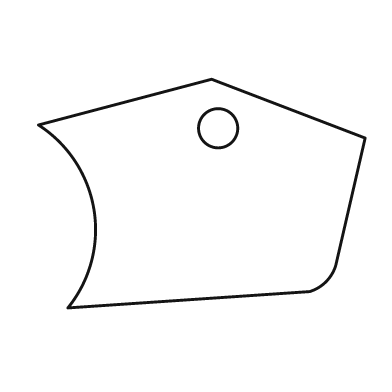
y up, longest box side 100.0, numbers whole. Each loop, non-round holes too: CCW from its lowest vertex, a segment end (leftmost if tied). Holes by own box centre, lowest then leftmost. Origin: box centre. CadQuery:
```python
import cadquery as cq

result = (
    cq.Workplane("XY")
    .moveTo(-41.0, -35.0)
    .lineTo(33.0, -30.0)
    .threePointArc((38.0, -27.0), (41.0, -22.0))
    .lineTo(50.0, 17.0)
    .lineTo(3.0, 35.0)
    .lineTo(-50.0, 21.0)
    .threePointArc((-33.0, -5.0), (-41.0, -35.0))
    .close()
    .moveTo(5.0, 20.0)
    .circle(6.0)
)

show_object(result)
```